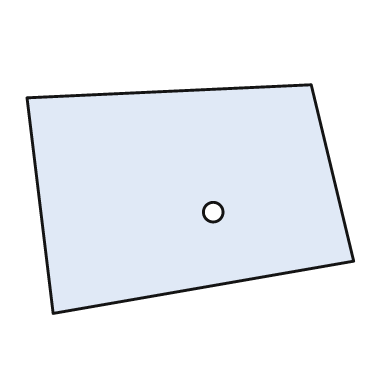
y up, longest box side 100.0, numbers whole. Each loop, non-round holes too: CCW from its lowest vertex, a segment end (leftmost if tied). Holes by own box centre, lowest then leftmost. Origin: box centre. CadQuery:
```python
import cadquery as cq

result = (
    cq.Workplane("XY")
    .moveTo(-42.0, -35.0)
    .lineTo(50.0, -19.0)
    .lineTo(37.0, 35.0)
    .lineTo(-50.0, 31.0)
    .close()
    .moveTo(7.0, -4.0)
    .circle(3.0)
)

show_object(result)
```